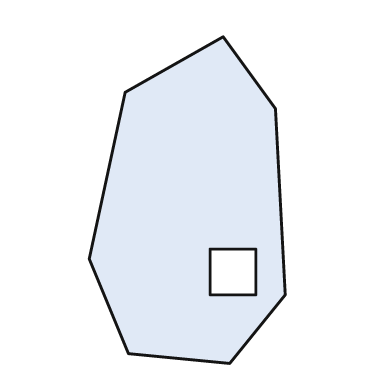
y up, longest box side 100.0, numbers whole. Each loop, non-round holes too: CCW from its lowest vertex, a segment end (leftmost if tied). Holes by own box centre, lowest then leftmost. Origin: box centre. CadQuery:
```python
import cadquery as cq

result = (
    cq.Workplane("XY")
    .moveTo(13.0, -50.0)
    .lineTo(30.0, -29.0)
    .lineTo(27.0, 28.0)
    .lineTo(11.0, 50.0)
    .lineTo(-19.0, 33.0)
    .lineTo(-30.0, -18.0)
    .lineTo(-18.0, -47.0)
    .close()
    .moveTo(7.0, -29.0)
    .lineTo(21.0, -29.0)
    .lineTo(21.0, -15.0)
    .lineTo(7.0, -15.0)
    .close()
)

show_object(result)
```